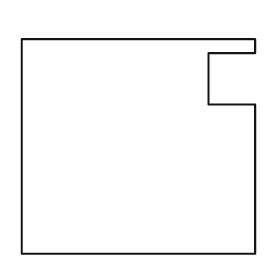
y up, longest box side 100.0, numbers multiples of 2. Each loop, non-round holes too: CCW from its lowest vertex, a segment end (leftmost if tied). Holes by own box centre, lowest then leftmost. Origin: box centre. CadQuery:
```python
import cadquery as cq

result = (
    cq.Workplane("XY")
    .moveTo(-50.0, -46.0)
    .lineTo(50.0, -46.0)
    .lineTo(50.0, 18.0)
    .lineTo(30.0, 18.0)
    .lineTo(30.0, 40.0)
    .lineTo(50.0, 40.0)
    .lineTo(50.0, 46.0)
    .lineTo(-50.0, 46.0)
    .close()
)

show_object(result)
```